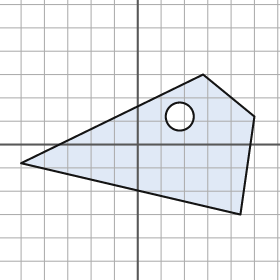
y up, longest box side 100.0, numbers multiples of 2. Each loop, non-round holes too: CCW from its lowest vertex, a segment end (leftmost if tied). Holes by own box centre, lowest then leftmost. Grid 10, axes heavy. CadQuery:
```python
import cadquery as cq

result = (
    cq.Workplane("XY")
    .moveTo(44.0, -30.0)
    .lineTo(50.0, 12.0)
    .lineTo(28.0, 30.0)
    .lineTo(-50.0, -8.0)
    .close()
    .moveTo(18.0, 12.0)
    .circle(6.0)
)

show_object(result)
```